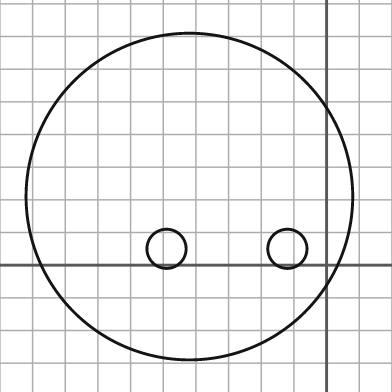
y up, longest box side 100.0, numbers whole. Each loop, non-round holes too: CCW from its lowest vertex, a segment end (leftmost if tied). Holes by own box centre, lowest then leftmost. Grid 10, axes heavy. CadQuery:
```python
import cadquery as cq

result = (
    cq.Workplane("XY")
    .moveTo(-42.0, 21.0)
    .circle(50.0)
    .moveTo(-49.0, 5.0)
    .circle(6.0)
    .moveTo(-12.0, 5.0)
    .circle(6.0)
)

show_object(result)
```